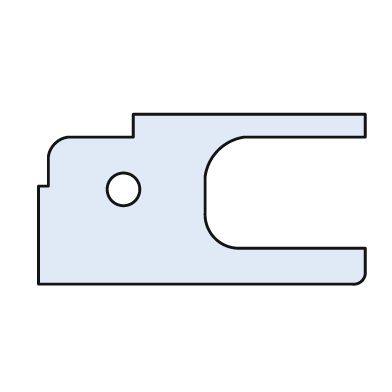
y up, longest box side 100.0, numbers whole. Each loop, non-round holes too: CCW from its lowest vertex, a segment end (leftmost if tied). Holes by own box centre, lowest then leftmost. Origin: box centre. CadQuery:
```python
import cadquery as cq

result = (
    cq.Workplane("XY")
    .moveTo(-50.0, -26.0)
    .lineTo(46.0, -26.0)
    .threePointArc((49.0, -25.0), (50.0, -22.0))
    .lineTo(50.0, -15.0)
    .lineTo(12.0, -15.0)
    .threePointArc((4.0, -12.0), (1.0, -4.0))
    .lineTo(1.0, 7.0)
    .threePointArc((5.0, 15.0), (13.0, 19.0))
    .lineTo(50.0, 19.0)
    .lineTo(50.0, 26.0)
    .lineTo(-21.0, 26.0)
    .lineTo(-21.0, 19.0)
    .lineTo(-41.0, 19.0)
    .threePointArc((-45.0, 17.0), (-47.0, 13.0))
    .lineTo(-47.0, 4.0)
    .lineTo(-50.0, 4.0)
    .close()
    .moveTo(-24.0, 3.0)
    .circle(5.0)
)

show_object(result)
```